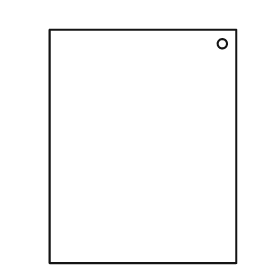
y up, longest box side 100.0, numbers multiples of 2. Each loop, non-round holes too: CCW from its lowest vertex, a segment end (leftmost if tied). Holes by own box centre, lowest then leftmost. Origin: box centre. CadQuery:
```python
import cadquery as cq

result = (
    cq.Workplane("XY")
    .moveTo(-40.0, -50.0)
    .lineTo(40.0, -50.0)
    .lineTo(40.0, 50.0)
    .lineTo(-40.0, 50.0)
    .close()
    .moveTo(34.0, 44.0)
    .circle(2.0)
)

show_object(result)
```